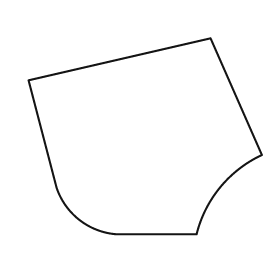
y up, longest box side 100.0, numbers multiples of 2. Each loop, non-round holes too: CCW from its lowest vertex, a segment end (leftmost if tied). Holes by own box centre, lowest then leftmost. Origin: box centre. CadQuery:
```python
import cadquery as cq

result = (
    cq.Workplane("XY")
    .moveTo(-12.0, -42.0)
    .lineTo(22.0, -42.0)
    .threePointArc((32.0, -22.0), (50.0, -8.0))
    .lineTo(28.0, 42.0)
    .lineTo(-50.0, 24.0)
    .lineTo(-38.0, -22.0)
    .threePointArc((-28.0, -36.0), (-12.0, -42.0))
    .close()
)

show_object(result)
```